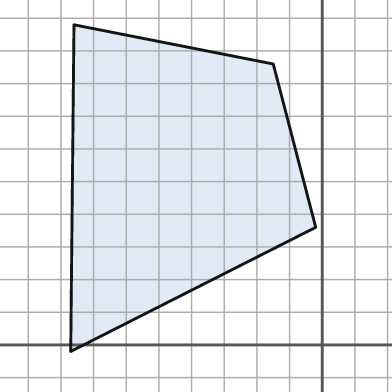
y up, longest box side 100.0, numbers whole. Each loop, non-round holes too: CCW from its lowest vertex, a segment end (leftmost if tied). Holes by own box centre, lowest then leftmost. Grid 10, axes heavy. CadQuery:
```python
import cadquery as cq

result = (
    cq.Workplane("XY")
    .moveTo(-77.0, -2.0)
    .lineTo(-2.0, 36.0)
    .lineTo(-15.0, 86.0)
    .lineTo(-76.0, 98.0)
    .close()
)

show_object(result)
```